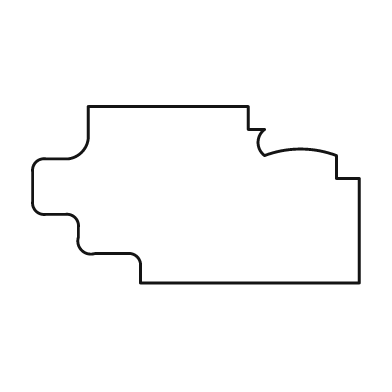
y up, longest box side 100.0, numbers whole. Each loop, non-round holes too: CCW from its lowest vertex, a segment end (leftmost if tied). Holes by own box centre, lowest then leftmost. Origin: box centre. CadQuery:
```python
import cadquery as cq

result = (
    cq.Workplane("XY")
    .moveTo(-17.0, -27.0)
    .lineTo(50.0, -27.0)
    .lineTo(50.0, 5.0)
    .lineTo(43.0, 5.0)
    .lineTo(43.0, 12.0)
    .threePointArc((32.0, 14.0), (21.0, 12.0))
    .threePointArc((19.0, 16.0), (21.0, 20.0))
    .lineTo(16.0, 20.0)
    .lineTo(16.0, 27.0)
    .lineTo(-33.0, 27.0)
    .lineTo(-33.0, 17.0)
    .threePointArc((-35.0, 13.0), (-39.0, 11.0))
    .lineTo(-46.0, 11.0)
    .threePointArc((-49.0, 10.0), (-50.0, 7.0))
    .lineTo(-50.0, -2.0)
    .threePointArc((-49.0, -5.0), (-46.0, -6.0))
    .lineTo(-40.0, -6.0)
    .threePointArc((-37.0, -7.0), (-36.0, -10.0))
    .lineTo(-36.0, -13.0)
    .threePointArc((-35.0, -17.0), (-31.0, -18.0))
    .lineTo(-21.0, -18.0)
    .threePointArc((-18.0, -19.0), (-17.0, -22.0))
    .close()
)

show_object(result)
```